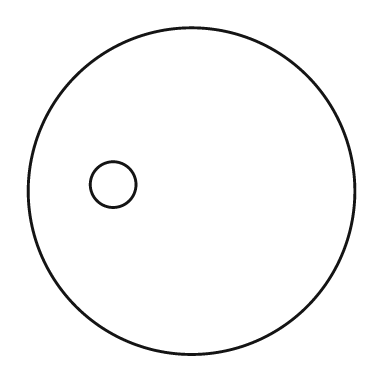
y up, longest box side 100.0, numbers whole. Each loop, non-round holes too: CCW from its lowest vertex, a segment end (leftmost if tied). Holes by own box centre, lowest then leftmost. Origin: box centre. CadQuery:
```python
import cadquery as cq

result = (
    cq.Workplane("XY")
    .moveTo(0.0, 0.0)
    .circle(50.0)
    .moveTo(-24.0, 2.0)
    .circle(7.0)
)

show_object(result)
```